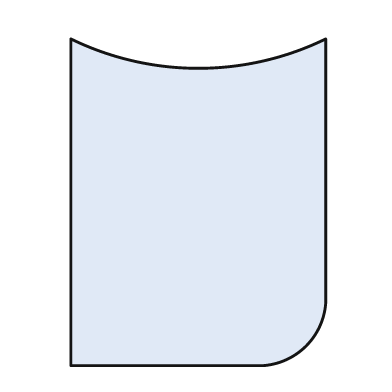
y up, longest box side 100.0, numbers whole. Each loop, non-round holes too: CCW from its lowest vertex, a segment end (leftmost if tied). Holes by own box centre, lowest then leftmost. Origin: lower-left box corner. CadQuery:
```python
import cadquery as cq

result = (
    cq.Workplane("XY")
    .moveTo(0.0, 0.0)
    .lineTo(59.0, 0.0)
    .threePointArc((72.0, 6.0), (78.0, 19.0))
    .lineTo(78.0, 100.0)
    .threePointArc((39.0, 91.0), (0.0, 100.0))
    .close()
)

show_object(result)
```